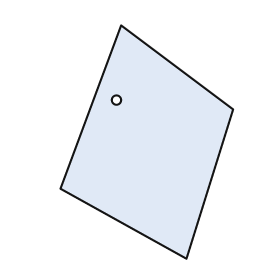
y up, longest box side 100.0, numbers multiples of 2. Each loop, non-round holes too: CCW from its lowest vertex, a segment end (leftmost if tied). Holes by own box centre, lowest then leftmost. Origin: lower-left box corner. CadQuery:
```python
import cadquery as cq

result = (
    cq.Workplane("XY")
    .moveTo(54.0, 0.0)
    .lineTo(74.0, 64.0)
    .lineTo(26.0, 100.0)
    .lineTo(0.0, 30.0)
    .close()
    .moveTo(24.0, 68.0)
    .circle(2.0)
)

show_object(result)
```